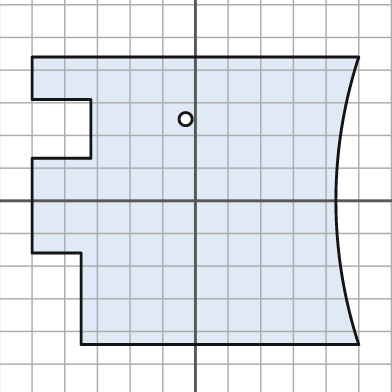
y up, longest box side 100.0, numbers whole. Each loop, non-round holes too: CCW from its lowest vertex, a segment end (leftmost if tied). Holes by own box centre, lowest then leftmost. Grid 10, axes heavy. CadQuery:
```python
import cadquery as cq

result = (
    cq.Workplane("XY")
    .moveTo(-35.0, -44.0)
    .lineTo(50.0, -44.0)
    .threePointArc((43.0, 0.0), (50.0, 44.0))
    .lineTo(-50.0, 44.0)
    .lineTo(-50.0, 31.0)
    .lineTo(-32.0, 31.0)
    .lineTo(-32.0, 13.0)
    .lineTo(-50.0, 13.0)
    .lineTo(-50.0, -16.0)
    .lineTo(-35.0, -16.0)
    .close()
    .moveTo(-3.0, 25.0)
    .circle(2.0)
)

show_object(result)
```